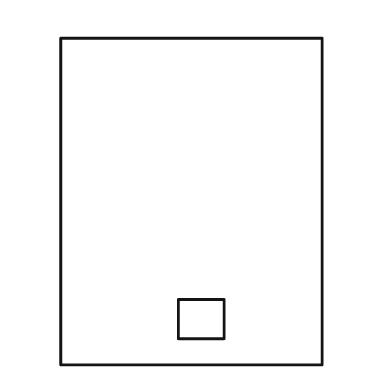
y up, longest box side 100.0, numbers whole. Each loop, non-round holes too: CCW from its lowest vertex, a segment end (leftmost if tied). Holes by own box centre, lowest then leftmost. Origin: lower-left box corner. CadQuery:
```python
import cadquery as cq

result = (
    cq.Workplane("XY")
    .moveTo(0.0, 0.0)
    .lineTo(80.0, 0.0)
    .lineTo(80.0, 100.0)
    .lineTo(0.0, 100.0)
    .close()
    .moveTo(36.0, 8.0)
    .lineTo(50.0, 8.0)
    .lineTo(50.0, 20.0)
    .lineTo(36.0, 20.0)
    .close()
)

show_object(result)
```